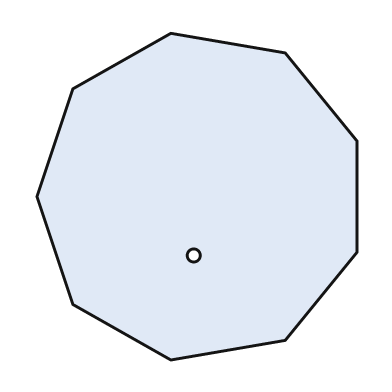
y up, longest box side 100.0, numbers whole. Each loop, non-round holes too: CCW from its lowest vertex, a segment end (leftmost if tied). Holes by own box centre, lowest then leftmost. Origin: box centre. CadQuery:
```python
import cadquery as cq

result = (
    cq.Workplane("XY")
    .moveTo(-8.0, -50.0)
    .lineTo(27.0, -44.0)
    .lineTo(49.0, -17.0)
    .lineTo(49.0, 17.0)
    .lineTo(27.0, 44.0)
    .lineTo(-8.0, 50.0)
    .lineTo(-38.0, 33.0)
    .lineTo(-49.0, 0.0)
    .lineTo(-38.0, -33.0)
    .close()
    .moveTo(-1.0, -18.0)
    .circle(2.0)
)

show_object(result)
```